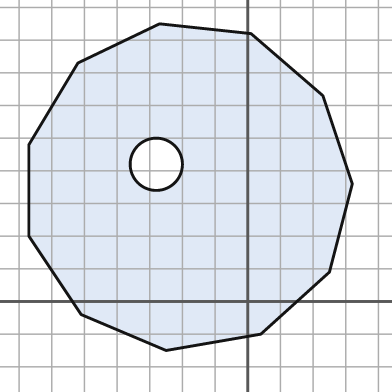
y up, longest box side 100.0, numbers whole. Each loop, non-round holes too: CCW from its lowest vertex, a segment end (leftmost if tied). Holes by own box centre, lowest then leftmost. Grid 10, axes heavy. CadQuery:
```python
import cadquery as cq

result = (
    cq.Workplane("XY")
    .moveTo(-25.0, -15.0)
    .lineTo(4.0, -10.0)
    .lineTo(25.0, 9.0)
    .lineTo(32.0, 36.0)
    .lineTo(23.0, 63.0)
    .lineTo(1.0, 82.0)
    .lineTo(-27.0, 85.0)
    .lineTo(-52.0, 73.0)
    .lineTo(-67.0, 48.0)
    .lineTo(-67.0, 20.0)
    .lineTo(-51.0, -4.0)
    .close()
    .moveTo(-28.0, 42.0)
    .circle(8.0)
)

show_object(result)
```